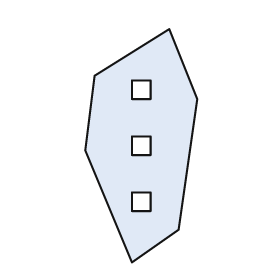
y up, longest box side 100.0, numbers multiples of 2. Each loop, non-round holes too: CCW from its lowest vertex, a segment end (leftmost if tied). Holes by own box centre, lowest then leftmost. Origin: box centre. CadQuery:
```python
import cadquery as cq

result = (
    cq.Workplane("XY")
    .moveTo(-4.0, -50.0)
    .lineTo(16.0, -36.0)
    .lineTo(24.0, 20.0)
    .lineTo(12.0, 50.0)
    .lineTo(-20.0, 30.0)
    .lineTo(-24.0, -2.0)
    .close()
    .moveTo(-4.0, -28.0)
    .lineTo(4.0, -28.0)
    .lineTo(4.0, -20.0)
    .lineTo(-4.0, -20.0)
    .close()
    .moveTo(-4.0, -4.0)
    .lineTo(4.0, -4.0)
    .lineTo(4.0, 4.0)
    .lineTo(-4.0, 4.0)
    .close()
    .moveTo(-4.0, 20.0)
    .lineTo(4.0, 20.0)
    .lineTo(4.0, 28.0)
    .lineTo(-4.0, 28.0)
    .close()
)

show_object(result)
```